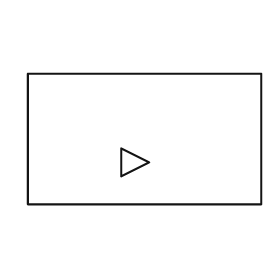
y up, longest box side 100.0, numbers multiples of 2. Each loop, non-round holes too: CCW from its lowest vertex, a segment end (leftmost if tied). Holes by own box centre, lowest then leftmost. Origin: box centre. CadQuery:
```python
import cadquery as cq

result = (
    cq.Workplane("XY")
    .moveTo(-50.0, -28.0)
    .lineTo(50.0, -28.0)
    .lineTo(50.0, 28.0)
    .lineTo(-50.0, 28.0)
    .close()
    .moveTo(-10.0, -16.0)
    .lineTo(2.0, -10.0)
    .lineTo(-10.0, -4.0)
    .close()
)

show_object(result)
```